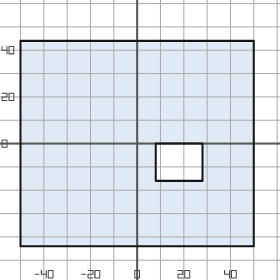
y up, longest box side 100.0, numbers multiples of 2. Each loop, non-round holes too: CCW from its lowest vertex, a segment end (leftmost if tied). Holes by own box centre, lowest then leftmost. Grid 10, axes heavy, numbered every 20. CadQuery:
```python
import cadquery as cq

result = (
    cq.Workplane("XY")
    .moveTo(-50.0, -44.0)
    .lineTo(50.0, -44.0)
    .lineTo(50.0, 44.0)
    .lineTo(-50.0, 44.0)
    .close()
    .moveTo(8.0, -16.0)
    .lineTo(28.0, -16.0)
    .lineTo(28.0, 0.0)
    .lineTo(8.0, 0.0)
    .close()
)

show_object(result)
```